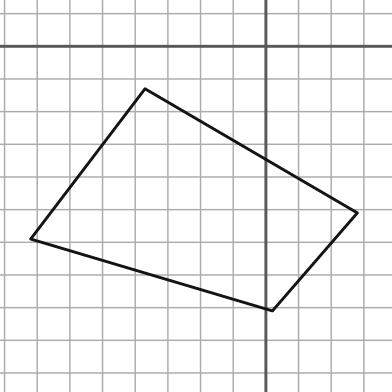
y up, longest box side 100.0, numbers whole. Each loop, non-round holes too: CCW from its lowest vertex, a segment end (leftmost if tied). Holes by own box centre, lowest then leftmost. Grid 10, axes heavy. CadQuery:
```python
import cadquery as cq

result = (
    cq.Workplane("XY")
    .moveTo(2.0, -81.0)
    .lineTo(28.0, -51.0)
    .lineTo(-37.0, -13.0)
    .lineTo(-72.0, -59.0)
    .close()
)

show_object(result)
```